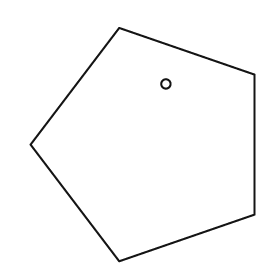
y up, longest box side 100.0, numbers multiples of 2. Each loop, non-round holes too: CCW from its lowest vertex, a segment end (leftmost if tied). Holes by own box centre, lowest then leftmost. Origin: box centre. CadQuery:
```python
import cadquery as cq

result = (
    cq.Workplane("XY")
    .moveTo(-10.0, -50.0)
    .lineTo(48.0, -30.0)
    .lineTo(48.0, 30.0)
    .lineTo(-10.0, 50.0)
    .lineTo(-48.0, 0.0)
    .close()
    .moveTo(10.0, 26.0)
    .circle(2.0)
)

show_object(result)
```